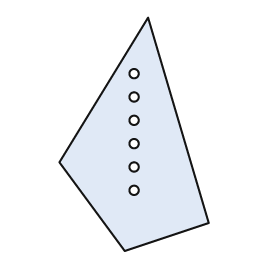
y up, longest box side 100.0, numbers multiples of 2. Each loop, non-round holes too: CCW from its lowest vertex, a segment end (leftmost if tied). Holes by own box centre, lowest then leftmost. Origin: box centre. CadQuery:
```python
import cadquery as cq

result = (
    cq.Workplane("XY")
    .moveTo(-4.0, -50.0)
    .lineTo(32.0, -38.0)
    .lineTo(6.0, 50.0)
    .lineTo(-32.0, -12.0)
    .close()
    .moveTo(0.0, -24.0)
    .circle(2.0)
    .moveTo(0.0, -14.0)
    .circle(2.0)
    .moveTo(0.0, -4.0)
    .circle(2.0)
    .moveTo(0.0, 6.0)
    .circle(2.0)
    .moveTo(0.0, 16.0)
    .circle(2.0)
    .moveTo(0.0, 26.0)
    .circle(2.0)
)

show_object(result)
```